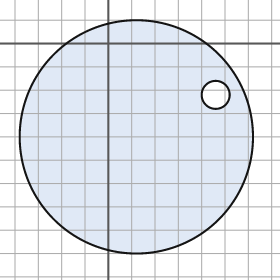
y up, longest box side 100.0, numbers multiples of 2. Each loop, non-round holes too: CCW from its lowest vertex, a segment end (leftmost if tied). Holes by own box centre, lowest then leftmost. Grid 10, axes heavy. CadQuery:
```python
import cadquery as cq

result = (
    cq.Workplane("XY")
    .moveTo(12.0, -40.0)
    .circle(50.0)
    .moveTo(46.0, -22.0)
    .circle(6.0)
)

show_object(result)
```